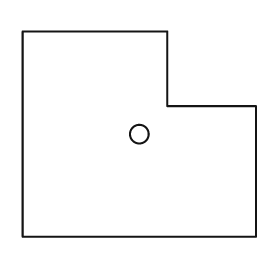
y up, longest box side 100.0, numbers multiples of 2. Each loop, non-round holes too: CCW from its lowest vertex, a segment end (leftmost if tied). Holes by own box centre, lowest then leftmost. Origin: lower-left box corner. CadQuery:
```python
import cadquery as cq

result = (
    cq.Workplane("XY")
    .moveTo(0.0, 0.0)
    .lineTo(100.0, 0.0)
    .lineTo(100.0, 56.0)
    .lineTo(62.0, 56.0)
    .lineTo(62.0, 88.0)
    .lineTo(0.0, 88.0)
    .close()
    .moveTo(50.0, 44.0)
    .circle(4.0)
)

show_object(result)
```